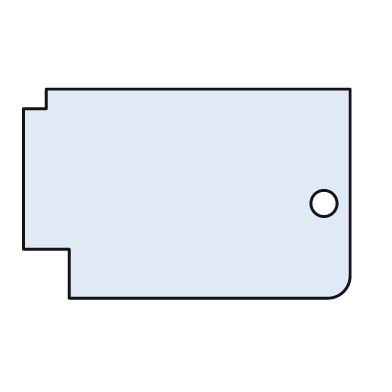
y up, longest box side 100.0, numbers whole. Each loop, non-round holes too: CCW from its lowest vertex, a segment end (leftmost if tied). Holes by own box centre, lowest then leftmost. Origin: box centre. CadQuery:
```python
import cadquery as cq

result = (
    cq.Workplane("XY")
    .moveTo(-36.0, -32.0)
    .lineTo(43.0, -32.0)
    .threePointArc((48.0, -30.0), (50.0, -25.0))
    .lineTo(50.0, 32.0)
    .lineTo(-43.0, 32.0)
    .lineTo(-43.0, 26.0)
    .lineTo(-50.0, 26.0)
    .lineTo(-50.0, -17.0)
    .lineTo(-36.0, -17.0)
    .close()
    .moveTo(42.0, -3.0)
    .circle(4.0)
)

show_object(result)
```